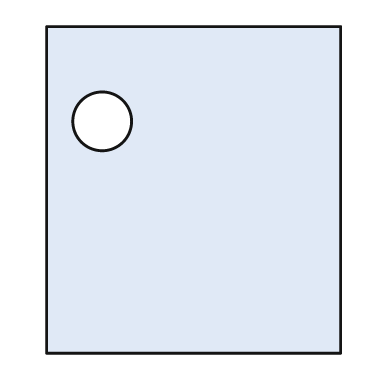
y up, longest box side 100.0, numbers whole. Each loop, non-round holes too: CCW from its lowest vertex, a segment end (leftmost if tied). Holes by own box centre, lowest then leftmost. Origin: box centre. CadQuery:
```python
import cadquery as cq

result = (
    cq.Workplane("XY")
    .moveTo(-45.0, -50.0)
    .lineTo(45.0, -50.0)
    .lineTo(45.0, 50.0)
    .lineTo(-45.0, 50.0)
    .close()
    .moveTo(-28.0, 21.0)
    .circle(9.0)
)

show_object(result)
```